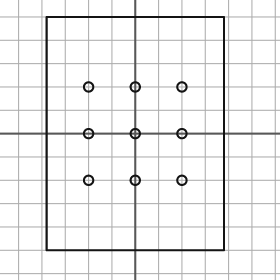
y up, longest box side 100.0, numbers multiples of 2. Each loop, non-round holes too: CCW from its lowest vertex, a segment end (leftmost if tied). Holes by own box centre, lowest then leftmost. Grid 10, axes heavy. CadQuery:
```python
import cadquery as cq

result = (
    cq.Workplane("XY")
    .moveTo(-38.0, -50.0)
    .lineTo(38.0, -50.0)
    .lineTo(38.0, 50.0)
    .lineTo(-38.0, 50.0)
    .close()
    .moveTo(-20.0, -20.0)
    .circle(2.0)
    .moveTo(0.0, -20.0)
    .circle(2.0)
    .moveTo(20.0, -20.0)
    .circle(2.0)
    .moveTo(-20.0, 0.0)
    .circle(2.0)
    .moveTo(0.0, 0.0)
    .circle(2.0)
    .moveTo(20.0, 0.0)
    .circle(2.0)
    .moveTo(-20.0, 20.0)
    .circle(2.0)
    .moveTo(0.0, 20.0)
    .circle(2.0)
    .moveTo(20.0, 20.0)
    .circle(2.0)
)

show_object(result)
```